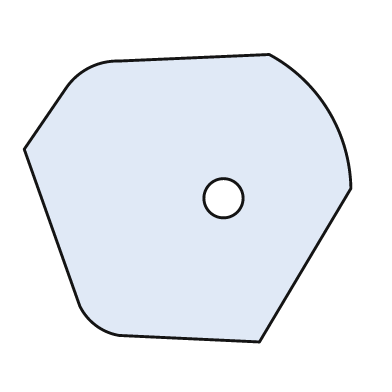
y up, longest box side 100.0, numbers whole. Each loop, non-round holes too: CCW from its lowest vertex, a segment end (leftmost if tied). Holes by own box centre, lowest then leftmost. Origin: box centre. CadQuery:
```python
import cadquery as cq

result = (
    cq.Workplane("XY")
    .moveTo(22.0, -44.0)
    .lineTo(50.0, 3.0)
    .threePointArc((43.0, 27.0), (25.0, 44.0))
    .lineTo(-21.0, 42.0)
    .threePointArc((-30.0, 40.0), (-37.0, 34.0))
    .lineTo(-50.0, 15.0)
    .lineTo(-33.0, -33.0)
    .threePointArc((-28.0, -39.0), (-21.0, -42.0))
    .close()
    .moveTo(11.0, 0.0)
    .circle(6.0)
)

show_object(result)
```